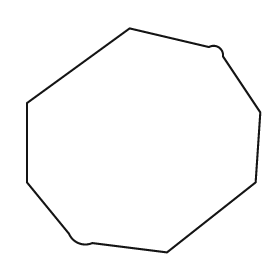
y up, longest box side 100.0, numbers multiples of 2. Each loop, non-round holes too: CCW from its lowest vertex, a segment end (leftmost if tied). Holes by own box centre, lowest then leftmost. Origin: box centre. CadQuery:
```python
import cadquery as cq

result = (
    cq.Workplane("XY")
    .moveTo(10.0, -48.0)
    .lineTo(48.0, -18.0)
    .lineTo(50.0, 12.0)
    .lineTo(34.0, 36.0)
    .threePointArc((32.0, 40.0), (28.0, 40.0))
    .lineTo(-6.0, 48.0)
    .lineTo(-50.0, 16.0)
    .lineTo(-50.0, -18.0)
    .lineTo(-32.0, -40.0)
    .threePointArc((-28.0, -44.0), (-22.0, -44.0))
    .close()
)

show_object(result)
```